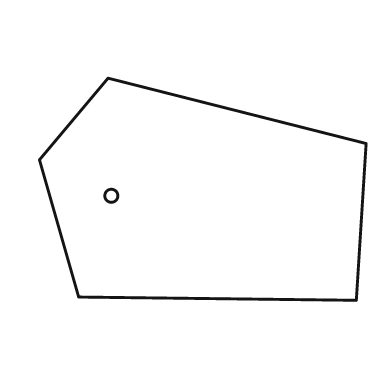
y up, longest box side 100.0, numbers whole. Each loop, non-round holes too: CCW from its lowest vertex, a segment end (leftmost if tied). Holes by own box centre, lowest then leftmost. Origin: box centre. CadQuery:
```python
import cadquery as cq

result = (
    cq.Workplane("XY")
    .moveTo(47.0, -34.0)
    .lineTo(50.0, 14.0)
    .lineTo(-29.0, 34.0)
    .lineTo(-50.0, 9.0)
    .lineTo(-38.0, -33.0)
    .close()
    .moveTo(-28.0, -2.0)
    .circle(2.0)
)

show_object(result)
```